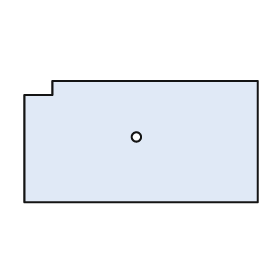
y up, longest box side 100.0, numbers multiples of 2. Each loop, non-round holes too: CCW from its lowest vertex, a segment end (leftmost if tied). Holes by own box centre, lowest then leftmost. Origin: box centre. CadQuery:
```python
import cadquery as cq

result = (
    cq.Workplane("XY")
    .moveTo(-50.0, -26.0)
    .lineTo(50.0, -26.0)
    .lineTo(50.0, 26.0)
    .lineTo(-38.0, 26.0)
    .lineTo(-38.0, 20.0)
    .lineTo(-50.0, 20.0)
    .close()
    .moveTo(-2.0, 2.0)
    .circle(2.0)
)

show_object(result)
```